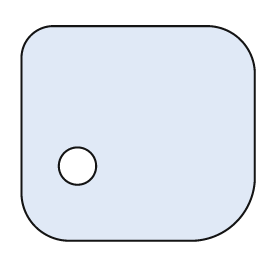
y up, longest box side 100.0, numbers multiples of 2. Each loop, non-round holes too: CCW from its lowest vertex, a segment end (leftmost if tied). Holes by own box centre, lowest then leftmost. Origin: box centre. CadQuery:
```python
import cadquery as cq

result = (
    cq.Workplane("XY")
    .moveTo(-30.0, -46.0)
    .lineTo(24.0, -46.0)
    .threePointArc((42.0, -38.0), (50.0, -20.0))
    .lineTo(50.0, 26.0)
    .threePointArc((44.0, 40.0), (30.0, 46.0))
    .lineTo(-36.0, 46.0)
    .threePointArc((-46.0, 42.0), (-50.0, 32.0))
    .lineTo(-50.0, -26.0)
    .threePointArc((-44.0, -40.0), (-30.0, -46.0))
    .close()
    .moveTo(-26.0, -14.0)
    .circle(8.0)
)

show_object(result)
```